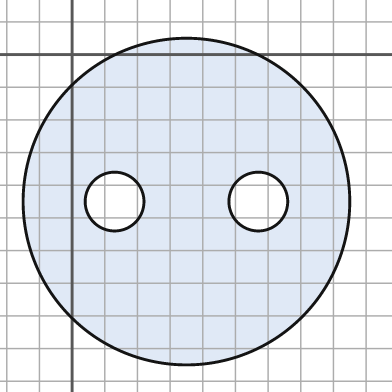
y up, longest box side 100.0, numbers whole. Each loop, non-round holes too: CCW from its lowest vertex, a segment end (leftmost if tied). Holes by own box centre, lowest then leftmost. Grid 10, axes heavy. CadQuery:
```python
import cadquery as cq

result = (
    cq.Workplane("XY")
    .moveTo(35.0, -45.0)
    .circle(50.0)
    .moveTo(13.0, -45.0)
    .circle(9.0)
    .moveTo(57.0, -45.0)
    .circle(9.0)
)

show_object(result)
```